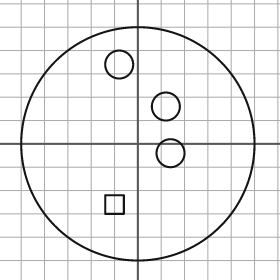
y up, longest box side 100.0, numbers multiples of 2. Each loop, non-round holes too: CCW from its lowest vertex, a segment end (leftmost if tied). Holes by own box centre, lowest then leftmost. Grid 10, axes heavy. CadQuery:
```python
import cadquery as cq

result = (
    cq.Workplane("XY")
    .moveTo(0.0, 0.0)
    .circle(50.0)
    .moveTo(-14.0, -30.0)
    .lineTo(-6.0, -30.0)
    .lineTo(-6.0, -22.0)
    .lineTo(-14.0, -22.0)
    .close()
    .moveTo(14.0, -4.0)
    .circle(6.0)
    .moveTo(12.0, 16.0)
    .circle(6.0)
    .moveTo(-8.0, 34.0)
    .circle(6.0)
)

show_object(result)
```